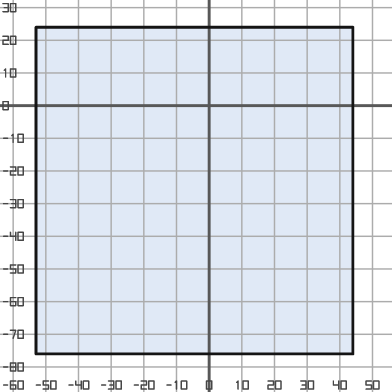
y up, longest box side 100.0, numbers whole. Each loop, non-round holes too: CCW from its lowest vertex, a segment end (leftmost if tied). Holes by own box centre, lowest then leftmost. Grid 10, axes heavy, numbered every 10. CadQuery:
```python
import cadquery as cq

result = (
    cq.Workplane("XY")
    .moveTo(-53.0, -76.0)
    .lineTo(44.0, -76.0)
    .lineTo(44.0, 24.0)
    .lineTo(-53.0, 24.0)
    .close()
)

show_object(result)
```